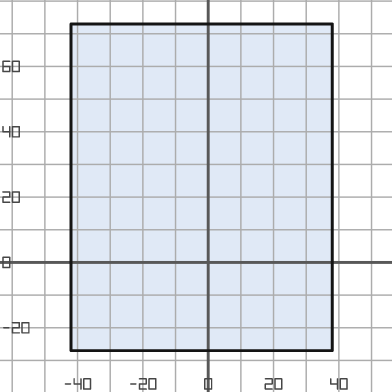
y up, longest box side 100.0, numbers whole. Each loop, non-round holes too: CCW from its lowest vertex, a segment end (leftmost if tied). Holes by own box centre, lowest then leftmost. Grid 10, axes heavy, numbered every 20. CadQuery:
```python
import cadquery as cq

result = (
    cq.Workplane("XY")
    .moveTo(-42.0, -27.0)
    .lineTo(38.0, -27.0)
    .lineTo(38.0, 73.0)
    .lineTo(-42.0, 73.0)
    .close()
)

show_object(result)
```